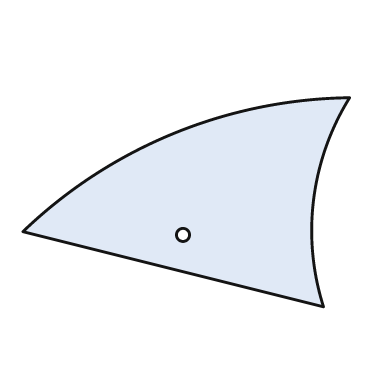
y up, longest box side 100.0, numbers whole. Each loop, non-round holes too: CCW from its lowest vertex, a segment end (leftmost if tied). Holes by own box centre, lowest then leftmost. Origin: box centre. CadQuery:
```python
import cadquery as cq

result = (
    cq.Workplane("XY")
    .moveTo(42.0, -32.0)
    .threePointArc((39.0, 1.0), (50.0, 32.0))
    .threePointArc((-4.0, 21.0), (-50.0, -9.0))
    .close()
    .moveTo(-1.0, -10.0)
    .circle(2.0)
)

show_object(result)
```